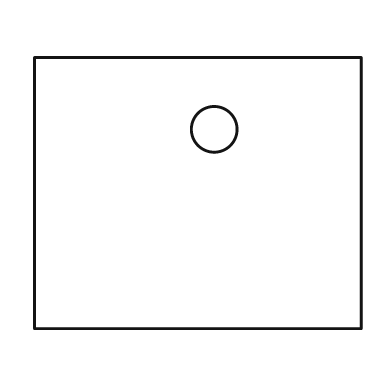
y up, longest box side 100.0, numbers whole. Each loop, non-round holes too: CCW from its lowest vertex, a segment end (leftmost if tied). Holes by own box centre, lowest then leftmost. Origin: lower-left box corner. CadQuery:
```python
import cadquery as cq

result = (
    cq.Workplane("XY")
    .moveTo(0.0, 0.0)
    .lineTo(100.0, 0.0)
    .lineTo(100.0, 83.0)
    .lineTo(0.0, 83.0)
    .close()
    .moveTo(55.0, 61.0)
    .circle(7.0)
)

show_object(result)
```